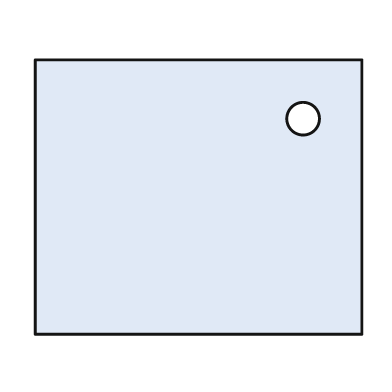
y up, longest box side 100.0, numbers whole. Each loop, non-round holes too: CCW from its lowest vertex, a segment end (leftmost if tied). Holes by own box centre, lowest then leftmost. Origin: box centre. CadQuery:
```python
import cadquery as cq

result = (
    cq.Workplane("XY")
    .moveTo(-50.0, -42.0)
    .lineTo(50.0, -42.0)
    .lineTo(50.0, 42.0)
    .lineTo(-50.0, 42.0)
    .close()
    .moveTo(32.0, 24.0)
    .circle(5.0)
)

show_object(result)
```